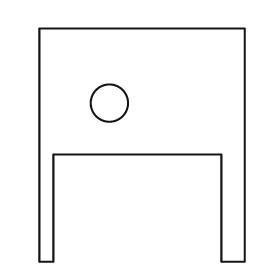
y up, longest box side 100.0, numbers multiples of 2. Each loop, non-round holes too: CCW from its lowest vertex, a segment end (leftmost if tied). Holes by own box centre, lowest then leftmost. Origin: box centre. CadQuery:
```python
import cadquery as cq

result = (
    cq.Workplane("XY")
    .moveTo(-44.0, -50.0)
    .lineTo(-38.0, -50.0)
    .lineTo(-38.0, -4.0)
    .lineTo(34.0, -4.0)
    .lineTo(34.0, -50.0)
    .lineTo(44.0, -50.0)
    .lineTo(44.0, 50.0)
    .lineTo(-44.0, 50.0)
    .close()
    .moveTo(-14.0, 18.0)
    .circle(8.0)
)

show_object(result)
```